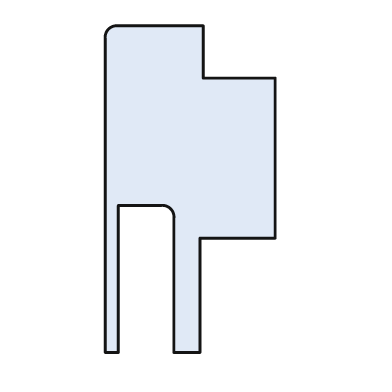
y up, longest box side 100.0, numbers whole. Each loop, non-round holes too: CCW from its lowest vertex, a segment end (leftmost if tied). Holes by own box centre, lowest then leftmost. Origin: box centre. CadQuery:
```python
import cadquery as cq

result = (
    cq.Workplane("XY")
    .moveTo(-26.0, -50.0)
    .lineTo(-22.0, -50.0)
    .lineTo(-22.0, -5.0)
    .lineTo(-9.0, -5.0)
    .threePointArc((-6.0, -6.0), (-5.0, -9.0))
    .lineTo(-5.0, -50.0)
    .lineTo(3.0, -50.0)
    .lineTo(3.0, -15.0)
    .lineTo(26.0, -15.0)
    .lineTo(26.0, 34.0)
    .lineTo(4.0, 34.0)
    .lineTo(4.0, 50.0)
    .lineTo(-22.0, 50.0)
    .threePointArc((-25.0, 49.0), (-26.0, 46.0))
    .close()
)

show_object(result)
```